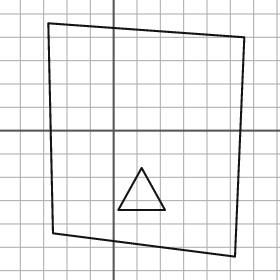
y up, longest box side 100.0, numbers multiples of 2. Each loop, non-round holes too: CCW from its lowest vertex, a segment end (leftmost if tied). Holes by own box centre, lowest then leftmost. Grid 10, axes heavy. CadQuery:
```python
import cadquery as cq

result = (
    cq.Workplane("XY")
    .moveTo(52.0, -54.0)
    .lineTo(56.0, 40.0)
    .lineTo(-28.0, 46.0)
    .lineTo(-26.0, -44.0)
    .close()
    .moveTo(2.0, -34.0)
    .lineTo(22.0, -34.0)
    .lineTo(12.0, -16.0)
    .close()
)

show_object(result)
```